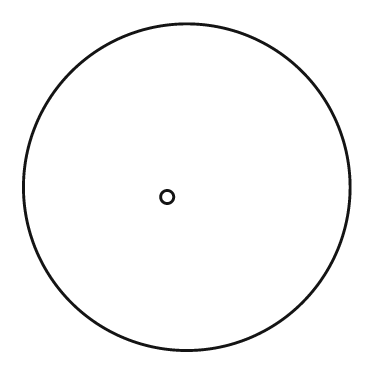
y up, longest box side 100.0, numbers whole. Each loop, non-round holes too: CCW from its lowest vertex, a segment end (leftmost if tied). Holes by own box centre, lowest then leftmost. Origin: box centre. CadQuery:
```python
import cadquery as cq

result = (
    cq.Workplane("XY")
    .moveTo(0.0, 0.0)
    .circle(50.0)
    .moveTo(-6.0, -3.0)
    .circle(2.0)
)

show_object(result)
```